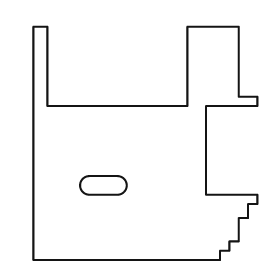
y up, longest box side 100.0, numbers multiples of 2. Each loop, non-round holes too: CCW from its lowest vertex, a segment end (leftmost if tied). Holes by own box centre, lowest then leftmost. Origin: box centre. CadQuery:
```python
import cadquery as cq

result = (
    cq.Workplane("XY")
    .moveTo(-48.0, -50.0)
    .lineTo(32.0, -50.0)
    .lineTo(32.0, -46.0)
    .lineTo(36.0, -46.0)
    .lineTo(36.0, -42.0)
    .lineTo(40.0, -42.0)
    .lineTo(40.0, -32.0)
    .lineTo(44.0, -32.0)
    .lineTo(44.0, -26.0)
    .lineTo(48.0, -26.0)
    .lineTo(48.0, -22.0)
    .lineTo(26.0, -22.0)
    .lineTo(26.0, 16.0)
    .lineTo(48.0, 16.0)
    .lineTo(48.0, 20.0)
    .lineTo(40.0, 20.0)
    .lineTo(40.0, 50.0)
    .lineTo(18.0, 50.0)
    .lineTo(18.0, 16.0)
    .lineTo(-42.0, 16.0)
    .lineTo(-42.0, 50.0)
    .lineTo(-48.0, 50.0)
    .close()
    .moveTo(-24.0, -22.0)
    .lineTo(-12.0, -22.0)
    .threePointArc((-8.0, -18.0), (-12.0, -14.0))
    .lineTo(-24.0, -14.0)
    .threePointArc((-28.0, -18.0), (-24.0, -22.0))
    .close()
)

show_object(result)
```